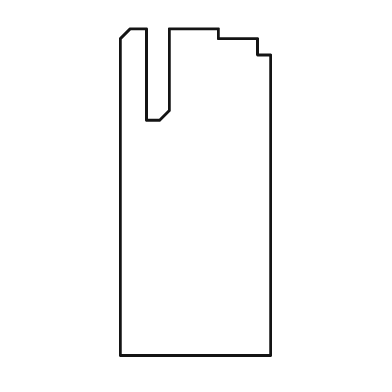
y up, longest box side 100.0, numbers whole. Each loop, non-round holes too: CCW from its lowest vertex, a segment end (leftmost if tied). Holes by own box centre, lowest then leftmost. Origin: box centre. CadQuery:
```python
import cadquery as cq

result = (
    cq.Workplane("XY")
    .moveTo(-23.0, -50.0)
    .lineTo(23.0, -50.0)
    .lineTo(23.0, 42.0)
    .lineTo(19.0, 42.0)
    .lineTo(19.0, 47.0)
    .lineTo(7.0, 47.0)
    .lineTo(7.0, 50.0)
    .lineTo(-8.0, 50.0)
    .lineTo(-8.0, 25.0)
    .lineTo(-11.0, 22.0)
    .lineTo(-15.0, 22.0)
    .lineTo(-15.0, 50.0)
    .lineTo(-20.0, 50.0)
    .lineTo(-23.0, 47.0)
    .close()
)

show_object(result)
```